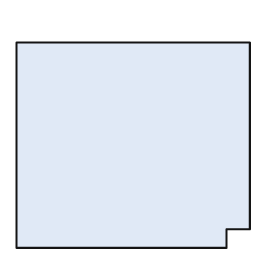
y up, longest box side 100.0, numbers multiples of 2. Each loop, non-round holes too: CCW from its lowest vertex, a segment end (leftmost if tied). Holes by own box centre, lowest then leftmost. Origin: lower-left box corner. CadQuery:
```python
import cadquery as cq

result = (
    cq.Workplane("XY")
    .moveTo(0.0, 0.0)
    .lineTo(90.0, 0.0)
    .lineTo(90.0, 8.0)
    .lineTo(100.0, 8.0)
    .lineTo(100.0, 88.0)
    .lineTo(0.0, 88.0)
    .close()
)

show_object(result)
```